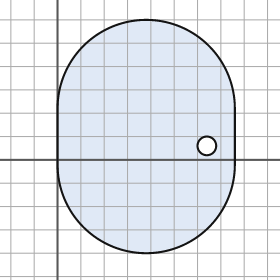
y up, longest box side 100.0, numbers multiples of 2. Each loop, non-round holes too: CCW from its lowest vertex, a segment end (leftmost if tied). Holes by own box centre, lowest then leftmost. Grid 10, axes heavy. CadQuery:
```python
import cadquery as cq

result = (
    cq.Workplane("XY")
    .moveTo(0.0, -2.0)
    .threePointArc((38.0, -40.0), (76.0, -2.0))
    .lineTo(76.0, 22.0)
    .threePointArc((38.0, 60.0), (0.0, 22.0))
    .close()
    .moveTo(64.0, 6.0)
    .circle(4.0)
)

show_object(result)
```